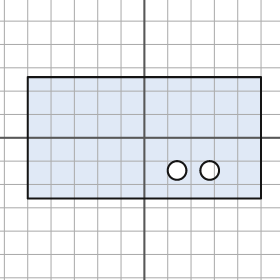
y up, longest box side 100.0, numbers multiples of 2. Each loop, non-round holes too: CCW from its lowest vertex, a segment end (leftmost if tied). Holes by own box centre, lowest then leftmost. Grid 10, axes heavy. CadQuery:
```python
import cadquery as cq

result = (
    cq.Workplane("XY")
    .moveTo(-50.0, -26.0)
    .lineTo(50.0, -26.0)
    .lineTo(50.0, 26.0)
    .lineTo(-50.0, 26.0)
    .close()
    .moveTo(14.0, -14.0)
    .circle(4.0)
    .moveTo(28.0, -14.0)
    .circle(4.0)
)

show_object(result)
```